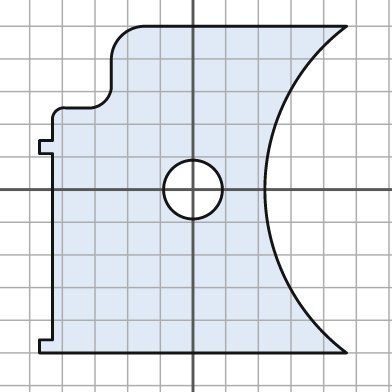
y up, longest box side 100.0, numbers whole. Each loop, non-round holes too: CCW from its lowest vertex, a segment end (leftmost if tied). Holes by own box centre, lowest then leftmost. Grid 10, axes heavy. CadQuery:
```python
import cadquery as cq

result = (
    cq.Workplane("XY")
    .moveTo(-47.0, -50.0)
    .lineTo(47.0, -50.0)
    .threePointArc((22.0, 0.0), (47.0, 50.0))
    .lineTo(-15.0, 50.0)
    .threePointArc((-22.0, 47.0), (-25.0, 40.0))
    .lineTo(-25.0, 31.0)
    .threePointArc((-27.0, 27.0), (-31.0, 25.0))
    .lineTo(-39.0, 25.0)
    .threePointArc((-42.0, 24.0), (-43.0, 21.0))
    .lineTo(-43.0, 15.0)
    .lineTo(-47.0, 15.0)
    .lineTo(-47.0, 11.0)
    .lineTo(-43.0, 11.0)
    .lineTo(-43.0, -46.0)
    .lineTo(-47.0, -46.0)
    .close()
    .moveTo(0.0, 0.0)
    .circle(9.0)
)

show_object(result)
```